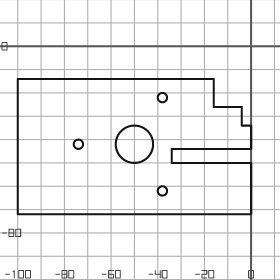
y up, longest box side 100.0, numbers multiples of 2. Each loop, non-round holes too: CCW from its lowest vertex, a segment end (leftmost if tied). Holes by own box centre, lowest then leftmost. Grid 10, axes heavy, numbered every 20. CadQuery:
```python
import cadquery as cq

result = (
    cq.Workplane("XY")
    .moveTo(-100.0, -72.0)
    .lineTo(0.0, -72.0)
    .lineTo(0.0, -50.0)
    .lineTo(-34.0, -50.0)
    .lineTo(-34.0, -44.0)
    .lineTo(0.0, -44.0)
    .lineTo(0.0, -34.0)
    .lineTo(-4.0, -34.0)
    .lineTo(-4.0, -26.0)
    .lineTo(-16.0, -26.0)
    .lineTo(-16.0, -14.0)
    .lineTo(-100.0, -14.0)
    .close()
    .moveTo(-38.0, -62.0)
    .circle(2.0)
    .moveTo(-74.0, -42.0)
    .circle(2.0)
    .moveTo(-50.0, -42.0)
    .circle(8.0)
    .moveTo(-38.0, -22.0)
    .circle(2.0)
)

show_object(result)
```